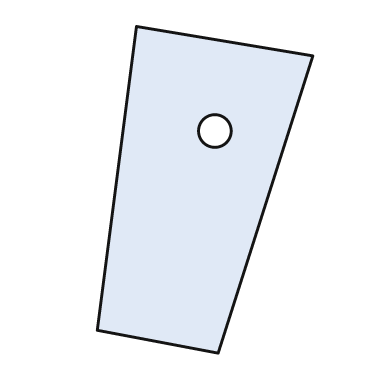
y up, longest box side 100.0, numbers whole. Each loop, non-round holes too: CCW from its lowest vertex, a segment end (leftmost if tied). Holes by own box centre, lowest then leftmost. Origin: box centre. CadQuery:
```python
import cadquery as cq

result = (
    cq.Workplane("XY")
    .moveTo(4.0, -50.0)
    .lineTo(33.0, 41.0)
    .lineTo(-21.0, 50.0)
    .lineTo(-33.0, -43.0)
    .close()
    .moveTo(3.0, 18.0)
    .circle(5.0)
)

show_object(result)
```